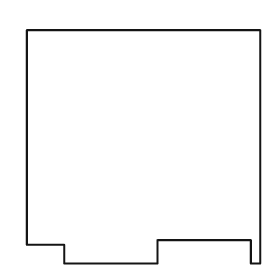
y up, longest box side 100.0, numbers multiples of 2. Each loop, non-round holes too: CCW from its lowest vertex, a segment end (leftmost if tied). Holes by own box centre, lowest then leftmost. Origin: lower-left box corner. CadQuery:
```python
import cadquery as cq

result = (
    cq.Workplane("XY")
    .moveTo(16.0, 0.0)
    .lineTo(56.0, 0.0)
    .lineTo(56.0, 10.0)
    .lineTo(96.0, 10.0)
    .lineTo(96.0, 0.0)
    .lineTo(100.0, 0.0)
    .lineTo(100.0, 100.0)
    .lineTo(0.0, 100.0)
    .lineTo(0.0, 8.0)
    .lineTo(16.0, 8.0)
    .close()
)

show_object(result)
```